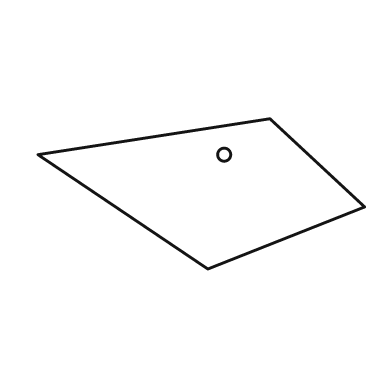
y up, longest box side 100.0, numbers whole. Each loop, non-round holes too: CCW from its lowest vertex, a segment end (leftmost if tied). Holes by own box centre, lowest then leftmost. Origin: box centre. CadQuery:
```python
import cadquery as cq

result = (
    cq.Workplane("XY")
    .moveTo(2.0, -23.0)
    .lineTo(50.0, -4.0)
    .lineTo(21.0, 23.0)
    .lineTo(-50.0, 12.0)
    .close()
    .moveTo(7.0, 12.0)
    .circle(2.0)
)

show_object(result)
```